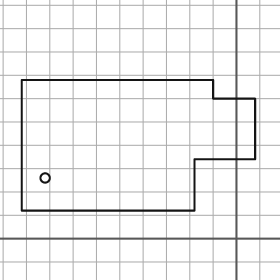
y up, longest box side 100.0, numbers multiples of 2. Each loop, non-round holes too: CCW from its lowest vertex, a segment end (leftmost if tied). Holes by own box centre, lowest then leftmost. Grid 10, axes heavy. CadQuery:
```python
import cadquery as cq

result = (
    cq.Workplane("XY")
    .moveTo(-92.0, 12.0)
    .lineTo(-18.0, 12.0)
    .lineTo(-18.0, 34.0)
    .lineTo(8.0, 34.0)
    .lineTo(8.0, 60.0)
    .lineTo(-10.0, 60.0)
    .lineTo(-10.0, 68.0)
    .lineTo(-92.0, 68.0)
    .close()
    .moveTo(-82.0, 26.0)
    .circle(2.0)
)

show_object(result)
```